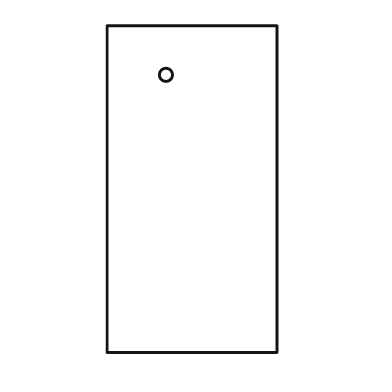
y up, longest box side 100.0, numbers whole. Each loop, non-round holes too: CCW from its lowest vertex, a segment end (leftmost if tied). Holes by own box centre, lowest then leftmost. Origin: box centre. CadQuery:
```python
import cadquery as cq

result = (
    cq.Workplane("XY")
    .moveTo(-26.0, -50.0)
    .lineTo(26.0, -50.0)
    .lineTo(26.0, 50.0)
    .lineTo(-26.0, 50.0)
    .close()
    .moveTo(-8.0, 35.0)
    .circle(2.0)
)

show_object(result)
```